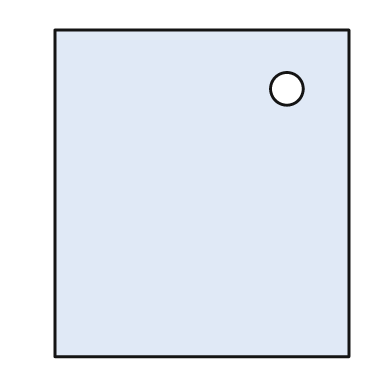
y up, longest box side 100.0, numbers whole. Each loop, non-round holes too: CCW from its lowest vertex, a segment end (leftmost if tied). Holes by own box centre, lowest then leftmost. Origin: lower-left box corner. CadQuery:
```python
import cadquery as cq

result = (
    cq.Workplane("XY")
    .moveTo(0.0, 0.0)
    .lineTo(90.0, 0.0)
    .lineTo(90.0, 100.0)
    .lineTo(0.0, 100.0)
    .close()
    .moveTo(71.0, 82.0)
    .circle(5.0)
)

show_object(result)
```